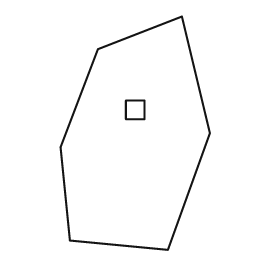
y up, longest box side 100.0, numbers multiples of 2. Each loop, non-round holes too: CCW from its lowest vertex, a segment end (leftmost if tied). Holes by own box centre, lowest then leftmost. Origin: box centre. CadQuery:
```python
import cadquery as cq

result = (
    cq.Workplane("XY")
    .moveTo(14.0, -50.0)
    .lineTo(32.0, 0.0)
    .lineTo(20.0, 50.0)
    .lineTo(-16.0, 36.0)
    .lineTo(-32.0, -6.0)
    .lineTo(-28.0, -46.0)
    .close()
    .moveTo(-4.0, 6.0)
    .lineTo(4.0, 6.0)
    .lineTo(4.0, 14.0)
    .lineTo(-4.0, 14.0)
    .close()
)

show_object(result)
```